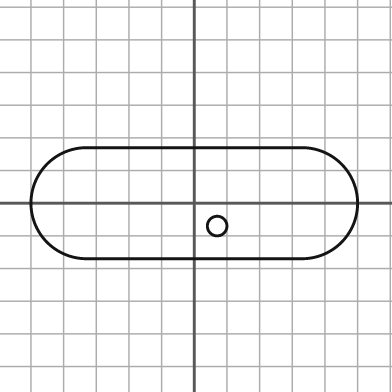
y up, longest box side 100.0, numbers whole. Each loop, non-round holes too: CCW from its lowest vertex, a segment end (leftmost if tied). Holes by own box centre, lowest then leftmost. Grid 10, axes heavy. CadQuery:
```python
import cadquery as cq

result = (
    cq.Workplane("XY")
    .moveTo(-33.0, -17.0)
    .lineTo(33.0, -17.0)
    .threePointArc((50.0, 0.0), (33.0, 17.0))
    .lineTo(-33.0, 17.0)
    .threePointArc((-50.0, 0.0), (-33.0, -17.0))
    .close()
    .moveTo(7.0, -7.0)
    .circle(3.0)
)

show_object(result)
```